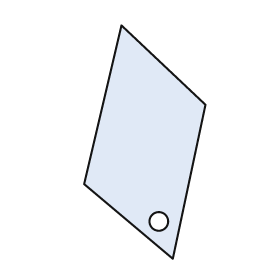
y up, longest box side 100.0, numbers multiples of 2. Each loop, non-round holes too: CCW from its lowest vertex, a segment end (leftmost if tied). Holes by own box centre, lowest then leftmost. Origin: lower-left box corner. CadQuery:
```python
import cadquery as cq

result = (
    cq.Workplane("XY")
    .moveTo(38.0, 0.0)
    .lineTo(52.0, 66.0)
    .lineTo(16.0, 100.0)
    .lineTo(0.0, 32.0)
    .close()
    .moveTo(32.0, 16.0)
    .circle(4.0)
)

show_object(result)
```